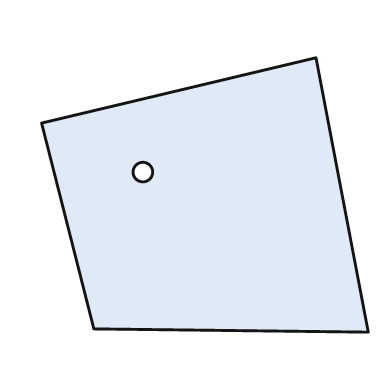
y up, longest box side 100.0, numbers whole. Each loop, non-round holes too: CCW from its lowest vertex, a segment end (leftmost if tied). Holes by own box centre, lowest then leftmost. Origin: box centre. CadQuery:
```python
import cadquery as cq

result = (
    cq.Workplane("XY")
    .moveTo(50.0, -42.0)
    .lineTo(34.0, 42.0)
    .lineTo(-50.0, 22.0)
    .lineTo(-34.0, -41.0)
    .close()
    .moveTo(-19.0, 7.0)
    .circle(3.0)
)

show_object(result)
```